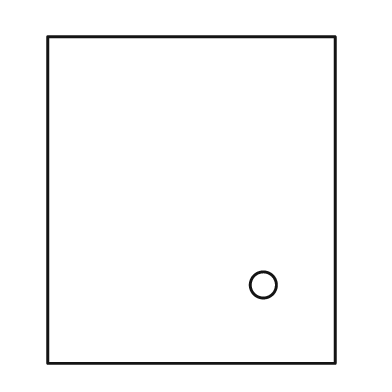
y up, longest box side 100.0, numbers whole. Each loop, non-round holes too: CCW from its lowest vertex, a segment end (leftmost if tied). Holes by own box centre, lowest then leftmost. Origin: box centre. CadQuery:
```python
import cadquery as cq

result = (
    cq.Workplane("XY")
    .moveTo(-44.0, -50.0)
    .lineTo(44.0, -50.0)
    .lineTo(44.0, 50.0)
    .lineTo(-44.0, 50.0)
    .close()
    .moveTo(22.0, -26.0)
    .circle(4.0)
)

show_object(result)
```